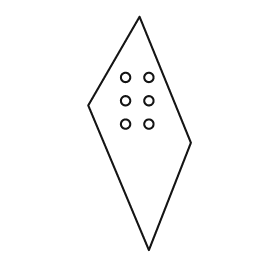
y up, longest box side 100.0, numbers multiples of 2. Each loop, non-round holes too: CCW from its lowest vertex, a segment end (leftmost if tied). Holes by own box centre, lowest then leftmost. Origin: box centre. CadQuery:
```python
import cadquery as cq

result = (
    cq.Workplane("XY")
    .moveTo(4.0, -50.0)
    .lineTo(22.0, -4.0)
    .lineTo(0.0, 50.0)
    .lineTo(-22.0, 12.0)
    .close()
    .moveTo(-6.0, 4.0)
    .circle(2.0)
    .moveTo(4.0, 4.0)
    .circle(2.0)
    .moveTo(-6.0, 14.0)
    .circle(2.0)
    .moveTo(4.0, 14.0)
    .circle(2.0)
    .moveTo(-6.0, 24.0)
    .circle(2.0)
    .moveTo(4.0, 24.0)
    .circle(2.0)
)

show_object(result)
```